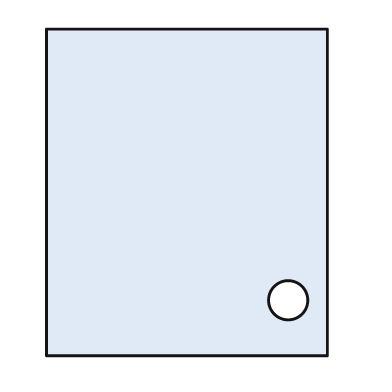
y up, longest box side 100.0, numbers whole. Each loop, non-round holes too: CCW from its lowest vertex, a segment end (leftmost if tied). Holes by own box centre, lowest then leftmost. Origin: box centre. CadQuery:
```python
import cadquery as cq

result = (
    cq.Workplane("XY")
    .moveTo(-43.0, -50.0)
    .lineTo(43.0, -50.0)
    .lineTo(43.0, 50.0)
    .lineTo(-43.0, 50.0)
    .close()
    .moveTo(31.0, -33.0)
    .circle(6.0)
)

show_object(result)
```